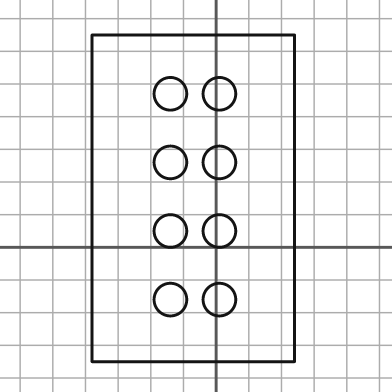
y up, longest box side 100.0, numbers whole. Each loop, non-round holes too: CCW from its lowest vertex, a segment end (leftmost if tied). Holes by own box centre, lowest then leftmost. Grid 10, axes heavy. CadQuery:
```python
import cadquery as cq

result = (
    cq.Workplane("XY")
    .moveTo(-38.0, -35.0)
    .lineTo(24.0, -35.0)
    .lineTo(24.0, 65.0)
    .lineTo(-38.0, 65.0)
    .close()
    .moveTo(-14.0, -16.0)
    .circle(5.0)
    .moveTo(1.0, -16.0)
    .circle(5.0)
    .moveTo(-14.0, 5.0)
    .circle(5.0)
    .moveTo(1.0, 5.0)
    .circle(5.0)
    .moveTo(-14.0, 26.0)
    .circle(5.0)
    .moveTo(1.0, 26.0)
    .circle(5.0)
    .moveTo(-14.0, 47.0)
    .circle(5.0)
    .moveTo(1.0, 47.0)
    .circle(5.0)
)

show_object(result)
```